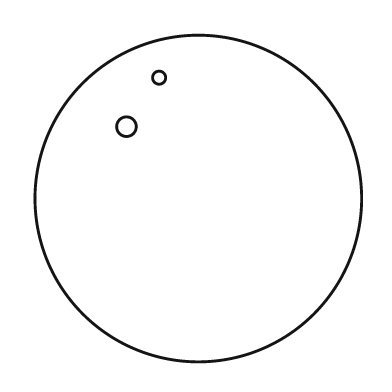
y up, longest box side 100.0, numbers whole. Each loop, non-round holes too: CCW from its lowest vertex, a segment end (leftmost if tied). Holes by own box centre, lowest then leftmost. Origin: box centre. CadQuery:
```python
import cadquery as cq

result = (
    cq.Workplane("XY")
    .moveTo(0.0, 0.0)
    .circle(50.0)
    .moveTo(-22.0, 22.0)
    .circle(3.0)
    .moveTo(-12.0, 37.0)
    .circle(2.0)
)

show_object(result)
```